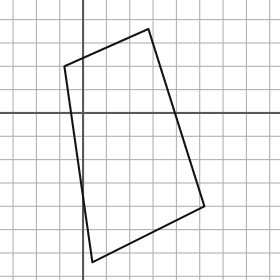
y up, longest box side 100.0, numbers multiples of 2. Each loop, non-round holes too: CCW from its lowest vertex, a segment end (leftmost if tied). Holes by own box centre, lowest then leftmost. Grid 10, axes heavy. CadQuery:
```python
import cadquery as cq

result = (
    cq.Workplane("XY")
    .moveTo(4.0, -64.0)
    .lineTo(52.0, -40.0)
    .lineTo(28.0, 36.0)
    .lineTo(-8.0, 20.0)
    .close()
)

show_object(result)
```